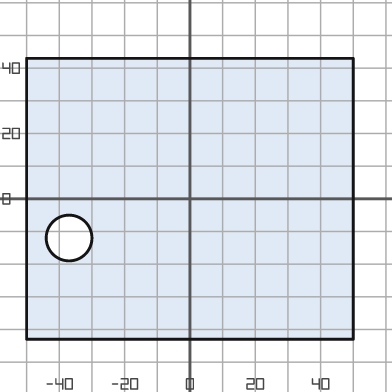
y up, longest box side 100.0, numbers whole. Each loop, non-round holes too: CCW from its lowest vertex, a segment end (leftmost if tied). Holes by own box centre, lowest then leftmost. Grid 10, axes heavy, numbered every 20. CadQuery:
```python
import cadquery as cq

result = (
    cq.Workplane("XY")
    .moveTo(-50.0, -43.0)
    .lineTo(50.0, -43.0)
    .lineTo(50.0, 43.0)
    .lineTo(-50.0, 43.0)
    .close()
    .moveTo(-37.0, -12.0)
    .circle(7.0)
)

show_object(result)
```